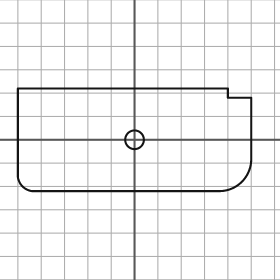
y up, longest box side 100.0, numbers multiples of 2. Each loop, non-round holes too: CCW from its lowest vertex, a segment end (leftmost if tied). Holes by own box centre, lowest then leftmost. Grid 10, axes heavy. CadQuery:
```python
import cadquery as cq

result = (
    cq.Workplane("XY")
    .moveTo(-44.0, -22.0)
    .lineTo(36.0, -22.0)
    .threePointArc((46.0, -18.0), (50.0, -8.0))
    .lineTo(50.0, 18.0)
    .lineTo(40.0, 18.0)
    .lineTo(40.0, 22.0)
    .lineTo(-50.0, 22.0)
    .lineTo(-50.0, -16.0)
    .threePointArc((-48.0, -20.0), (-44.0, -22.0))
    .close()
    .moveTo(0.0, 0.0)
    .circle(4.0)
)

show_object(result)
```